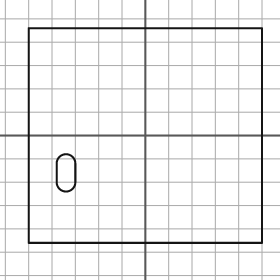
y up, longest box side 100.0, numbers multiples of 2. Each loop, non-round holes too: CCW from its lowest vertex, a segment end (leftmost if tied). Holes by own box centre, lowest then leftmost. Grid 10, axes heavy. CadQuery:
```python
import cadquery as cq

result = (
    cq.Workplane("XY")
    .moveTo(-50.0, -46.0)
    .lineTo(50.0, -46.0)
    .lineTo(50.0, 46.0)
    .lineTo(-50.0, 46.0)
    .close()
    .moveTo(-38.0, -20.0)
    .threePointArc((-34.0, -24.0), (-30.0, -20.0))
    .lineTo(-30.0, -12.0)
    .threePointArc((-34.0, -8.0), (-38.0, -12.0))
    .close()
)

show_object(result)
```